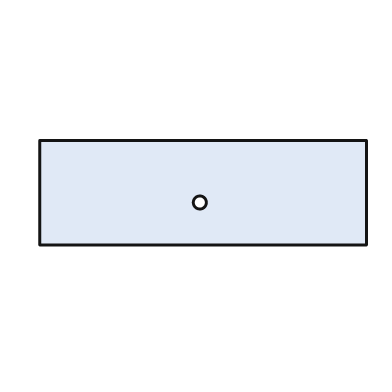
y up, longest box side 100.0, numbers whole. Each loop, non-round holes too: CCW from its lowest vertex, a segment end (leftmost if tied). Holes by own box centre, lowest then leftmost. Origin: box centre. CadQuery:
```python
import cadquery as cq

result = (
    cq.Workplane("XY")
    .moveTo(-50.0, -16.0)
    .lineTo(50.0, -16.0)
    .lineTo(50.0, 16.0)
    .lineTo(-50.0, 16.0)
    .close()
    .moveTo(-1.0, -3.0)
    .circle(2.0)
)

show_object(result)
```